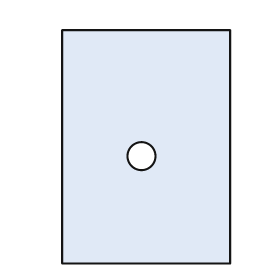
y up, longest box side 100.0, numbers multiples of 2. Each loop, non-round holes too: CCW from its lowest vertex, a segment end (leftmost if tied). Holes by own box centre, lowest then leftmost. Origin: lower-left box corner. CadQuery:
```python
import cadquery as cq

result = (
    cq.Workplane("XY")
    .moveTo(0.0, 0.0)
    .lineTo(72.0, 0.0)
    .lineTo(72.0, 100.0)
    .lineTo(0.0, 100.0)
    .close()
    .moveTo(34.0, 46.0)
    .circle(6.0)
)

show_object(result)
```